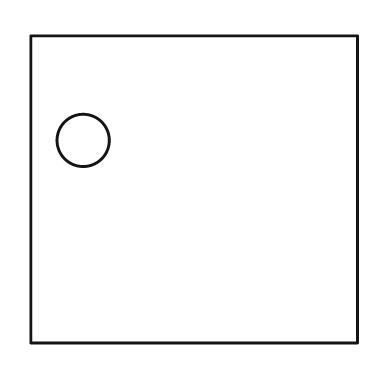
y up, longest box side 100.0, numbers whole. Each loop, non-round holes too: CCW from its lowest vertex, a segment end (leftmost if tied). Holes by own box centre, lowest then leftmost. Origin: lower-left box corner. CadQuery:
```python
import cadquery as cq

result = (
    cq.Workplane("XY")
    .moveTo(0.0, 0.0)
    .lineTo(100.0, 0.0)
    .lineTo(100.0, 94.0)
    .lineTo(0.0, 94.0)
    .close()
    .moveTo(16.0, 62.0)
    .circle(8.0)
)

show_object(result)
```